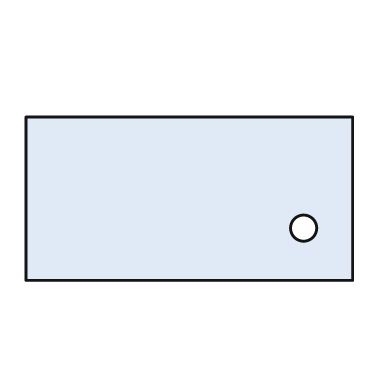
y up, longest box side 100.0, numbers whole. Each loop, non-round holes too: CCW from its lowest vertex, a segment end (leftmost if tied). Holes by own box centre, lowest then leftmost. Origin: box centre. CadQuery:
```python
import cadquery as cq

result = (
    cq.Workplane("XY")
    .moveTo(-50.0, -25.0)
    .lineTo(50.0, -25.0)
    .lineTo(50.0, 25.0)
    .lineTo(-50.0, 25.0)
    .close()
    .moveTo(35.0, -9.0)
    .circle(4.0)
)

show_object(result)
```